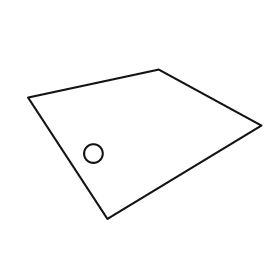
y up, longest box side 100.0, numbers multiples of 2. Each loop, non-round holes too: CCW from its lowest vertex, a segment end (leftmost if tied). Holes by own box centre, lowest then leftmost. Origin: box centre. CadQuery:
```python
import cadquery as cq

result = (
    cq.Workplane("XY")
    .moveTo(-16.0, -32.0)
    .lineTo(50.0, 8.0)
    .lineTo(6.0, 32.0)
    .lineTo(-50.0, 20.0)
    .close()
    .moveTo(-22.0, -4.0)
    .circle(4.0)
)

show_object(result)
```